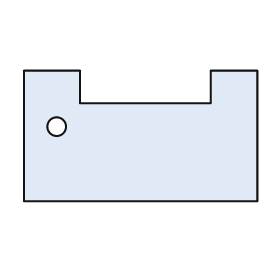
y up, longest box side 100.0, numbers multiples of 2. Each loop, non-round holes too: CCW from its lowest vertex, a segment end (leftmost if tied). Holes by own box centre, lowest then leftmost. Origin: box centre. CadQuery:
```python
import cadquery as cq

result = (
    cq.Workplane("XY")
    .moveTo(-50.0, -28.0)
    .lineTo(50.0, -28.0)
    .lineTo(50.0, 28.0)
    .lineTo(30.0, 28.0)
    .lineTo(30.0, 14.0)
    .lineTo(-26.0, 14.0)
    .lineTo(-26.0, 28.0)
    .lineTo(-50.0, 28.0)
    .close()
    .moveTo(-36.0, 4.0)
    .circle(4.0)
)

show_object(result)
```